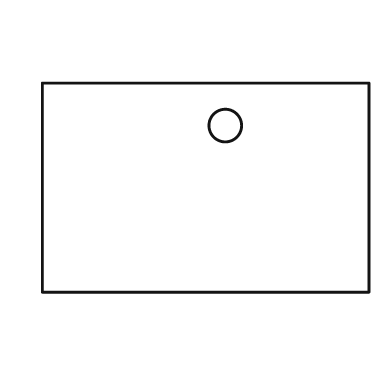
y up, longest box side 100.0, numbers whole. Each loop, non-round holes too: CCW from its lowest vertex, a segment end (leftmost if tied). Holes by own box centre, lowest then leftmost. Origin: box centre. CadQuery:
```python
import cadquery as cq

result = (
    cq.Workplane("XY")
    .moveTo(-50.0, -32.0)
    .lineTo(50.0, -32.0)
    .lineTo(50.0, 32.0)
    .lineTo(-50.0, 32.0)
    .close()
    .moveTo(6.0, 19.0)
    .circle(5.0)
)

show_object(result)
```